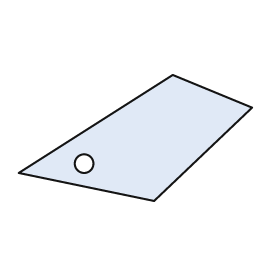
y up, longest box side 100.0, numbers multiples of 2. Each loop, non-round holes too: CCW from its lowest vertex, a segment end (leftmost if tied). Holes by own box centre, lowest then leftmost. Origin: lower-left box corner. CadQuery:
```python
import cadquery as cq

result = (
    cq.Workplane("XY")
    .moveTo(58.0, 0.0)
    .lineTo(100.0, 40.0)
    .lineTo(66.0, 54.0)
    .lineTo(0.0, 12.0)
    .close()
    .moveTo(28.0, 16.0)
    .circle(4.0)
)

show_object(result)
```